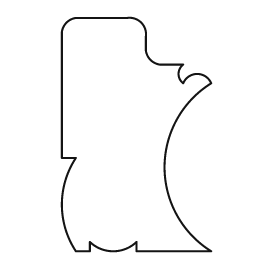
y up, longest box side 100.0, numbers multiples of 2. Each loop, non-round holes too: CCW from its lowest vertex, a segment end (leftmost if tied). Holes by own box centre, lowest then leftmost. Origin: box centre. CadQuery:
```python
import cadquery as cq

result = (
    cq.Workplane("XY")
    .moveTo(-26.0, -50.0)
    .lineTo(-20.0, -50.0)
    .lineTo(-20.0, -46.0)
    .threePointArc((-10.0, -50.0), (0.0, -46.0))
    .lineTo(0.0, -50.0)
    .lineTo(32.0, -50.0)
    .threePointArc((12.0, -14.0), (32.0, 22.0))
    .threePointArc((26.0, 26.0), (20.0, 22.0))
    .threePointArc((18.0, 26.0), (20.0, 30.0))
    .lineTo(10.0, 30.0)
    .threePointArc((6.0, 32.0), (4.0, 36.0))
    .lineTo(4.0, 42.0)
    .threePointArc((2.0, 48.0), (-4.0, 50.0))
    .lineTo(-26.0, 50.0)
    .threePointArc((-30.0, 48.0), (-32.0, 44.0))
    .lineTo(-32.0, -10.0)
    .lineTo(-26.0, -10.0)
    .threePointArc((-32.0, -30.0), (-26.0, -50.0))
    .close()
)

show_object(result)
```